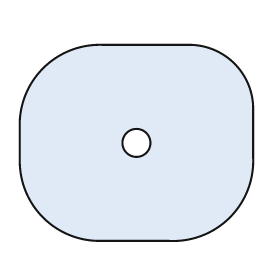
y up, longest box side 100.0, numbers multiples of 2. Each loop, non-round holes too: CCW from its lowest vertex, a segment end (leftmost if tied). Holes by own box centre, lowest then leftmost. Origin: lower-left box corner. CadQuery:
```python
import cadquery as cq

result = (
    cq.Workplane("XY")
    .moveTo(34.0, 0.0)
    .lineTo(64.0, 0.0)
    .threePointArc((90.0, 10.0), (100.0, 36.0))
    .lineTo(100.0, 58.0)
    .threePointArc((92.0, 76.0), (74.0, 84.0))
    .lineTo(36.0, 84.0)
    .threePointArc((10.0, 74.0), (0.0, 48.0))
    .lineTo(0.0, 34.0)
    .threePointArc((10.0, 10.0), (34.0, 0.0))
    .close()
    .moveTo(50.0, 42.0)
    .circle(6.0)
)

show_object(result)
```